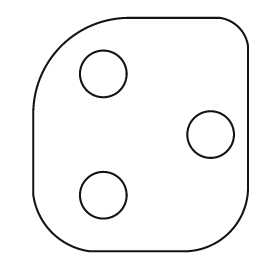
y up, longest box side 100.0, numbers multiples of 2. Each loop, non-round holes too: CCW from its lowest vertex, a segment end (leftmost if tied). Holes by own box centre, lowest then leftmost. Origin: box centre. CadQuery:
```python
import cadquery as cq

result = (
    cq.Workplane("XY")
    .moveTo(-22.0, -50.0)
    .lineTo(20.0, -50.0)
    .threePointArc((38.0, -42.0), (46.0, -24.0))
    .lineTo(46.0, 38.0)
    .threePointArc((42.0, 46.0), (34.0, 50.0))
    .lineTo(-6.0, 50.0)
    .threePointArc((-34.0, 38.0), (-46.0, 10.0))
    .lineTo(-46.0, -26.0)
    .threePointArc((-38.0, -42.0), (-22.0, -50.0))
    .close()
    .moveTo(-16.0, -26.0)
    .circle(10.0)
    .moveTo(30.0, 0.0)
    .circle(10.0)
    .moveTo(-16.0, 26.0)
    .circle(10.0)
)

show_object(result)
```